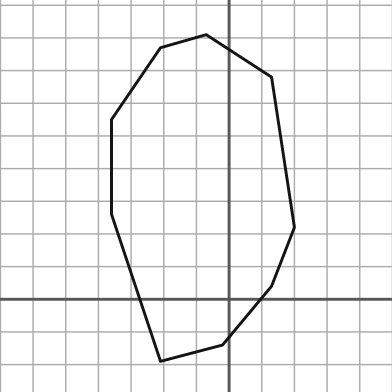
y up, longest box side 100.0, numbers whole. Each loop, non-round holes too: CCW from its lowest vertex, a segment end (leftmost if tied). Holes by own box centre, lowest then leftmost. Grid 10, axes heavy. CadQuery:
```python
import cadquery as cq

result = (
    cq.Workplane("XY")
    .moveTo(-21.0, -19.0)
    .lineTo(-2.0, -14.0)
    .lineTo(13.0, 4.0)
    .lineTo(20.0, 22.0)
    .lineTo(13.0, 68.0)
    .lineTo(-7.0, 81.0)
    .lineTo(-21.0, 77.0)
    .lineTo(-36.0, 55.0)
    .lineTo(-36.0, 26.0)
    .close()
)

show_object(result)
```